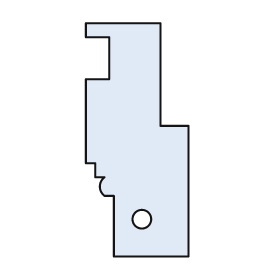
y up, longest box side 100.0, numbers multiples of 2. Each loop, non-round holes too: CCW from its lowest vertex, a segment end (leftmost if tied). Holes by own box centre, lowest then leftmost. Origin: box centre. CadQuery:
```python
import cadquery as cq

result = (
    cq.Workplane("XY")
    .moveTo(-10.0, -50.0)
    .lineTo(22.0, -50.0)
    .lineTo(22.0, 6.0)
    .lineTo(10.0, 6.0)
    .lineTo(10.0, 50.0)
    .lineTo(-22.0, 50.0)
    .lineTo(-22.0, 44.0)
    .lineTo(-12.0, 44.0)
    .lineTo(-12.0, 26.0)
    .lineTo(-22.0, 26.0)
    .lineTo(-22.0, -10.0)
    .lineTo(-18.0, -10.0)
    .lineTo(-18.0, -16.0)
    .lineTo(-14.0, -16.0)
    .threePointArc((-16.0, -20.0), (-14.0, -24.0))
    .lineTo(-10.0, -24.0)
    .close()
    .moveTo(2.0, -34.0)
    .circle(4.0)
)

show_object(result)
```